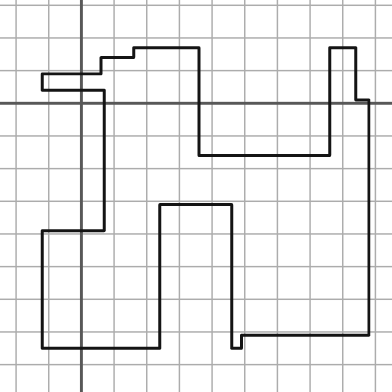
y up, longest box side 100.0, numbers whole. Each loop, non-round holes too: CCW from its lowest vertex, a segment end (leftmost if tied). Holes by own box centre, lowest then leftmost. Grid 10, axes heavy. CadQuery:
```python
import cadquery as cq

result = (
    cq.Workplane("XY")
    .moveTo(-12.0, -75.0)
    .lineTo(24.0, -75.0)
    .lineTo(24.0, -31.0)
    .lineTo(46.0, -31.0)
    .lineTo(46.0, -75.0)
    .lineTo(49.0, -75.0)
    .lineTo(49.0, -71.0)
    .lineTo(88.0, -71.0)
    .lineTo(88.0, 1.0)
    .lineTo(84.0, 1.0)
    .lineTo(84.0, 17.0)
    .lineTo(76.0, 17.0)
    .lineTo(76.0, -16.0)
    .lineTo(36.0, -16.0)
    .lineTo(36.0, 17.0)
    .lineTo(16.0, 17.0)
    .lineTo(16.0, 14.0)
    .lineTo(6.0, 14.0)
    .lineTo(6.0, 9.0)
    .lineTo(-12.0, 9.0)
    .lineTo(-12.0, 4.0)
    .lineTo(7.0, 4.0)
    .lineTo(7.0, -39.0)
    .lineTo(-12.0, -39.0)
    .close()
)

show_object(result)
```